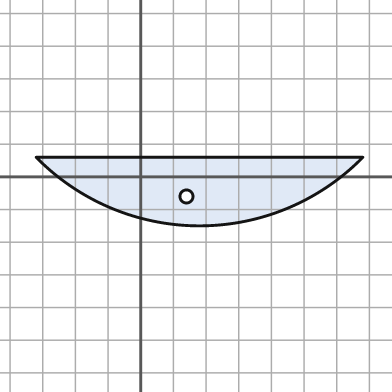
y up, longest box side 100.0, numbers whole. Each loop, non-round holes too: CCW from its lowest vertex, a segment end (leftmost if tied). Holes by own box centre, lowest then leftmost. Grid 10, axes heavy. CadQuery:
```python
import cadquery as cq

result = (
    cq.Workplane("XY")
    .moveTo(-32.0, 6.0)
    .threePointArc((18.0, -15.0), (68.0, 6.0))
    .close()
    .moveTo(14.0, -6.0)
    .circle(2.0)
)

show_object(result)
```